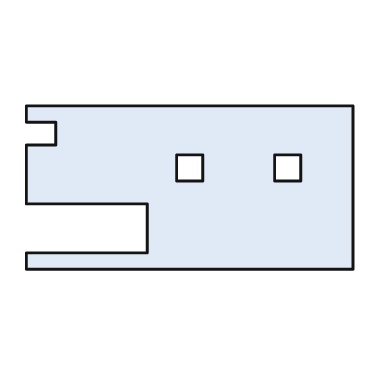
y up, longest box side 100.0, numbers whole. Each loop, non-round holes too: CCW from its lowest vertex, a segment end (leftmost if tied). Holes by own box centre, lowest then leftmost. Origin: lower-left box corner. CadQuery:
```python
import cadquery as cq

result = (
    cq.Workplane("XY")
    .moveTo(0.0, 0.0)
    .lineTo(100.0, 0.0)
    .lineTo(100.0, 50.0)
    .lineTo(0.0, 50.0)
    .lineTo(0.0, 45.0)
    .lineTo(9.0, 45.0)
    .lineTo(9.0, 38.0)
    .lineTo(0.0, 38.0)
    .lineTo(0.0, 20.0)
    .lineTo(37.0, 20.0)
    .lineTo(37.0, 5.0)
    .lineTo(0.0, 5.0)
    .close()
    .moveTo(46.0, 27.0)
    .lineTo(54.0, 27.0)
    .lineTo(54.0, 35.0)
    .lineTo(46.0, 35.0)
    .close()
    .moveTo(76.0, 27.0)
    .lineTo(84.0, 27.0)
    .lineTo(84.0, 35.0)
    .lineTo(76.0, 35.0)
    .close()
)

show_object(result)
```